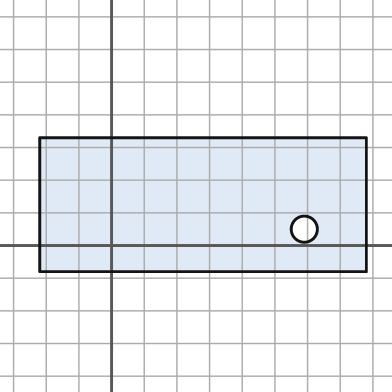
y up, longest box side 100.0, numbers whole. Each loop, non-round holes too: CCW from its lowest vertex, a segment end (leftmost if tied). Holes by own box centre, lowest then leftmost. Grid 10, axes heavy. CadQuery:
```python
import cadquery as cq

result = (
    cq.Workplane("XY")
    .moveTo(-22.0, -8.0)
    .lineTo(78.0, -8.0)
    .lineTo(78.0, 33.0)
    .lineTo(-22.0, 33.0)
    .close()
    .moveTo(59.0, 5.0)
    .circle(4.0)
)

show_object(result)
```